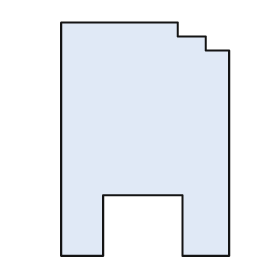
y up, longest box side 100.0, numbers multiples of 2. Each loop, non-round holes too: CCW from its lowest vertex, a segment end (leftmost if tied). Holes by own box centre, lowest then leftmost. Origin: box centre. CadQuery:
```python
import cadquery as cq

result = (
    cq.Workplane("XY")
    .moveTo(-36.0, -50.0)
    .lineTo(-18.0, -50.0)
    .lineTo(-18.0, -24.0)
    .lineTo(16.0, -24.0)
    .lineTo(16.0, -50.0)
    .lineTo(36.0, -50.0)
    .lineTo(36.0, 38.0)
    .lineTo(26.0, 38.0)
    .lineTo(26.0, 44.0)
    .lineTo(14.0, 44.0)
    .lineTo(14.0, 50.0)
    .lineTo(-36.0, 50.0)
    .close()
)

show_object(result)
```